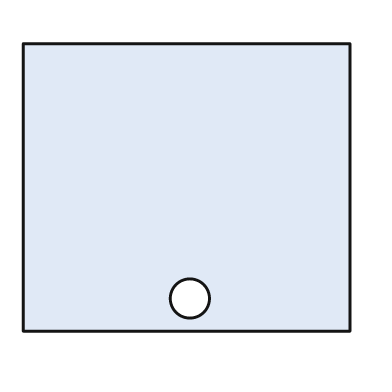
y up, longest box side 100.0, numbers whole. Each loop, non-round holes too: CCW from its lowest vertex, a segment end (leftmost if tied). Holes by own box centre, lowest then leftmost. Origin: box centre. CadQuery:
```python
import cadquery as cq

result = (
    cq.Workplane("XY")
    .moveTo(-50.0, -44.0)
    .lineTo(50.0, -44.0)
    .lineTo(50.0, 44.0)
    .lineTo(-50.0, 44.0)
    .close()
    .moveTo(1.0, -34.0)
    .circle(6.0)
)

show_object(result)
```